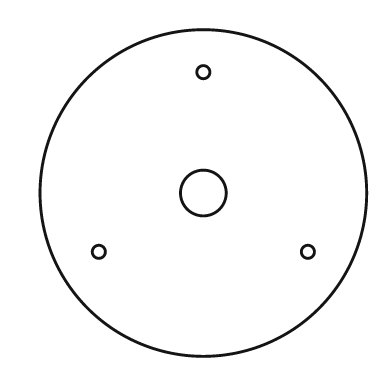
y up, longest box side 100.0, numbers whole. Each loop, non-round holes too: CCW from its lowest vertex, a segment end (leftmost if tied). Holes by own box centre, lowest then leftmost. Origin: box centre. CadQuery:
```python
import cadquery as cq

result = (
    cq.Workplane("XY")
    .moveTo(0.0, 0.0)
    .circle(50.0)
    .moveTo(-32.0, -18.0)
    .circle(2.0)
    .moveTo(32.0, -18.0)
    .circle(2.0)
    .moveTo(0.0, 0.0)
    .circle(7.0)
    .moveTo(0.0, 37.0)
    .circle(2.0)
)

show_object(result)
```